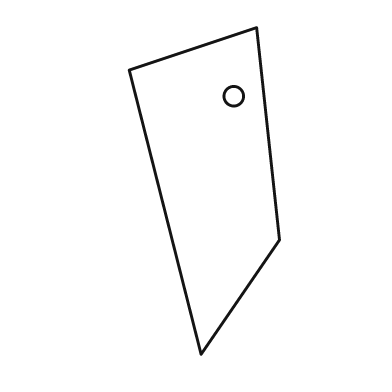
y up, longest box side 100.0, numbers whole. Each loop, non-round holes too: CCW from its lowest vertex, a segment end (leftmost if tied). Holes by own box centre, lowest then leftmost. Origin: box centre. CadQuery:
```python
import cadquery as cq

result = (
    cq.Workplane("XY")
    .moveTo(-1.0, -50.0)
    .lineTo(23.0, -15.0)
    .lineTo(16.0, 50.0)
    .lineTo(-23.0, 37.0)
    .close()
    .moveTo(9.0, 29.0)
    .circle(3.0)
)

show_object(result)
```